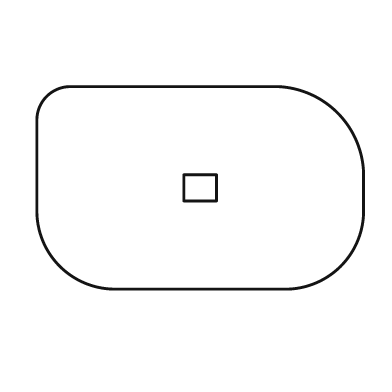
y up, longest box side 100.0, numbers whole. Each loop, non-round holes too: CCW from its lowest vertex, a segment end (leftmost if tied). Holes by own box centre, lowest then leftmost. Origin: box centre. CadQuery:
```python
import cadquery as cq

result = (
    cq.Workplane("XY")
    .moveTo(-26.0, -31.0)
    .lineTo(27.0, -31.0)
    .threePointArc((43.0, -24.0), (50.0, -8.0))
    .lineTo(50.0, 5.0)
    .threePointArc((42.0, 23.0), (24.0, 31.0))
    .lineTo(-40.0, 31.0)
    .threePointArc((-47.0, 28.0), (-50.0, 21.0))
    .lineTo(-50.0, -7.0)
    .threePointArc((-43.0, -24.0), (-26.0, -31.0))
    .close()
    .moveTo(-5.0, -4.0)
    .lineTo(5.0, -4.0)
    .lineTo(5.0, 4.0)
    .lineTo(-5.0, 4.0)
    .close()
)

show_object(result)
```